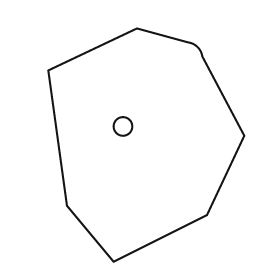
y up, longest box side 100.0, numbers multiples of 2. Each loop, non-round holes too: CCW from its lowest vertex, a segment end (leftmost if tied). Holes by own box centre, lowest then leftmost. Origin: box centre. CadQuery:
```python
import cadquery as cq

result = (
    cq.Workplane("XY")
    .moveTo(-14.0, -50.0)
    .lineTo(26.0, -30.0)
    .lineTo(42.0, 4.0)
    .lineTo(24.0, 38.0)
    .threePointArc((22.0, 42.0), (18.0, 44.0))
    .lineTo(-4.0, 50.0)
    .lineTo(-42.0, 32.0)
    .lineTo(-34.0, -26.0)
    .close()
    .moveTo(-10.0, 8.0)
    .circle(4.0)
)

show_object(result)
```